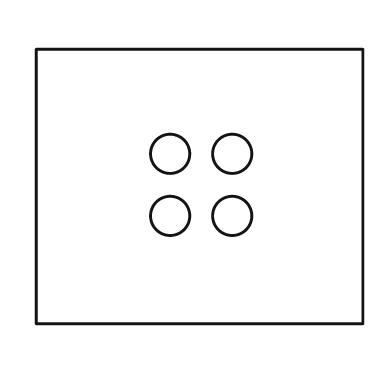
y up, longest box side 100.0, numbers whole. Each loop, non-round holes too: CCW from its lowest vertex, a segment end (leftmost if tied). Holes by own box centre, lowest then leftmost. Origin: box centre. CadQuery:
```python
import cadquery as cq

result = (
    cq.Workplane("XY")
    .moveTo(-50.0, -42.0)
    .lineTo(50.0, -42.0)
    .lineTo(50.0, 42.0)
    .lineTo(-50.0, 42.0)
    .close()
    .moveTo(-9.0, -9.0)
    .circle(6.0)
    .moveTo(10.0, -9.0)
    .circle(6.0)
    .moveTo(-9.0, 10.0)
    .circle(6.0)
    .moveTo(10.0, 10.0)
    .circle(6.0)
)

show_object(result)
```